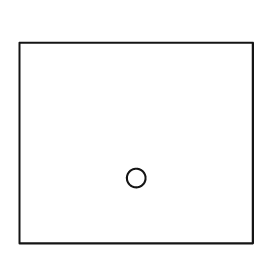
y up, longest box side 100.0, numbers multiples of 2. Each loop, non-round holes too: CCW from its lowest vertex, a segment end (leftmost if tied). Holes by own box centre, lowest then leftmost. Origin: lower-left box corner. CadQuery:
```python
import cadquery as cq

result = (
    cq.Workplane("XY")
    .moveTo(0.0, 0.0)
    .lineTo(100.0, 0.0)
    .lineTo(100.0, 86.0)
    .lineTo(0.0, 86.0)
    .close()
    .moveTo(50.0, 28.0)
    .circle(4.0)
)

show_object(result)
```